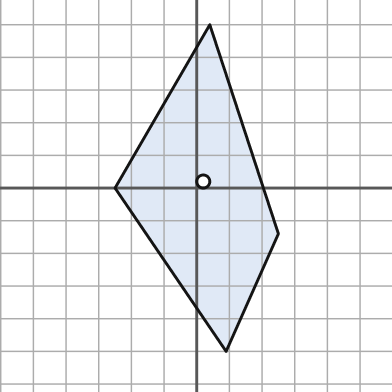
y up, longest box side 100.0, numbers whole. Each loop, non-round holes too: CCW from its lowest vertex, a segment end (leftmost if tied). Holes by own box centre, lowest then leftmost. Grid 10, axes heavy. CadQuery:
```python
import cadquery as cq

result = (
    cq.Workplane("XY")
    .moveTo(9.0, -50.0)
    .lineTo(25.0, -14.0)
    .lineTo(4.0, 50.0)
    .lineTo(-25.0, 0.0)
    .close()
    .moveTo(2.0, 2.0)
    .circle(2.0)
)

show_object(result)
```